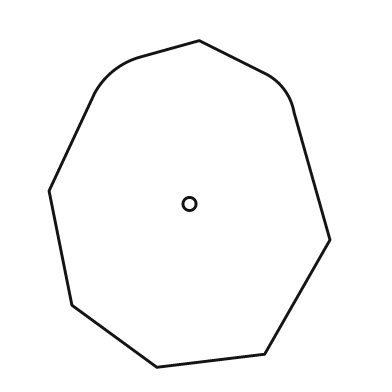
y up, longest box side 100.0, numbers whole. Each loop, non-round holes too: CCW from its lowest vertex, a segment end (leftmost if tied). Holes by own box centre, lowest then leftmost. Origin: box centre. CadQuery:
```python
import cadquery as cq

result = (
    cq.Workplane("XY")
    .moveTo(-10.0, -50.0)
    .lineTo(23.0, -46.0)
    .lineTo(43.0, -11.0)
    .lineTo(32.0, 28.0)
    .threePointArc((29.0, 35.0), (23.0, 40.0))
    .lineTo(3.0, 50.0)
    .lineTo(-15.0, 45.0)
    .threePointArc((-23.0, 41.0), (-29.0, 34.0))
    .lineTo(-43.0, 4.0)
    .lineTo(-36.0, -31.0)
    .close()
    .moveTo(0.0, 0.0)
    .circle(2.0)
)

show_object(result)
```